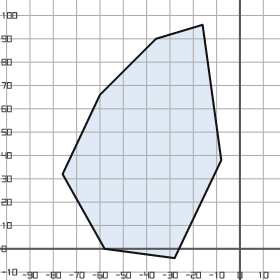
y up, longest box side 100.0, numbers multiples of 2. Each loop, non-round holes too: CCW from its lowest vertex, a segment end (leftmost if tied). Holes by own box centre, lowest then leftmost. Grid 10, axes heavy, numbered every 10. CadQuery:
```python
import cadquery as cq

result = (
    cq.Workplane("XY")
    .moveTo(-28.0, -4.0)
    .lineTo(-8.0, 38.0)
    .lineTo(-16.0, 96.0)
    .lineTo(-36.0, 90.0)
    .lineTo(-60.0, 66.0)
    .lineTo(-76.0, 32.0)
    .lineTo(-58.0, 0.0)
    .close()
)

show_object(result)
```